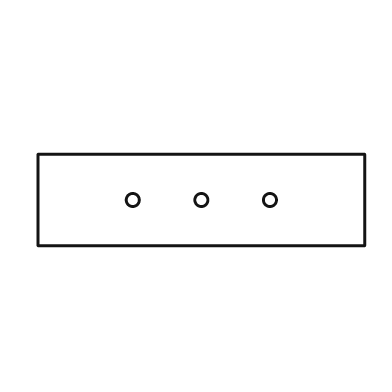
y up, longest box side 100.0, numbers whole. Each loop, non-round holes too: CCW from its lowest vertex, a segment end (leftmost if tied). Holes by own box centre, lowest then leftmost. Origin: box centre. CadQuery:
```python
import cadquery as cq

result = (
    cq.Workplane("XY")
    .moveTo(-50.0, -14.0)
    .lineTo(50.0, -14.0)
    .lineTo(50.0, 14.0)
    .lineTo(-50.0, 14.0)
    .close()
    .moveTo(-21.0, 0.0)
    .circle(2.0)
    .moveTo(0.0, 0.0)
    .circle(2.0)
    .moveTo(21.0, 0.0)
    .circle(2.0)
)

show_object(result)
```